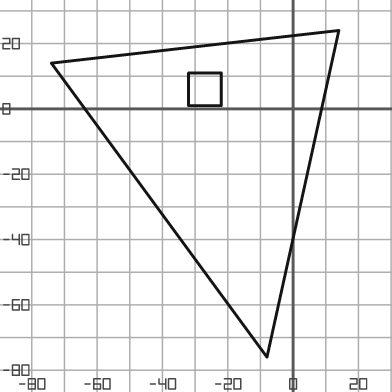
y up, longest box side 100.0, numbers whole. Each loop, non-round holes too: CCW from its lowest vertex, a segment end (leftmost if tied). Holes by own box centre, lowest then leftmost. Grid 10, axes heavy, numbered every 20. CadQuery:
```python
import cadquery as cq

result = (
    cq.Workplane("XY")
    .moveTo(-8.0, -76.0)
    .lineTo(14.0, 24.0)
    .lineTo(-74.0, 14.0)
    .close()
    .moveTo(-32.0, 1.0)
    .lineTo(-22.0, 1.0)
    .lineTo(-22.0, 11.0)
    .lineTo(-32.0, 11.0)
    .close()
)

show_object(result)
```